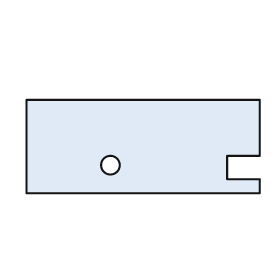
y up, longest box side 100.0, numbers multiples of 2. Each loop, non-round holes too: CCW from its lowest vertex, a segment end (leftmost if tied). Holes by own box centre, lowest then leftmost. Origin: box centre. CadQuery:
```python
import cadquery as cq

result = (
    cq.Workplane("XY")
    .moveTo(-50.0, -20.0)
    .lineTo(50.0, -20.0)
    .lineTo(50.0, -14.0)
    .lineTo(36.0, -14.0)
    .lineTo(36.0, -4.0)
    .lineTo(50.0, -4.0)
    .lineTo(50.0, 20.0)
    .lineTo(-50.0, 20.0)
    .close()
    .moveTo(-14.0, -8.0)
    .circle(4.0)
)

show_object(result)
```